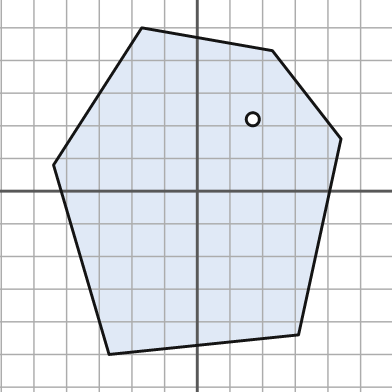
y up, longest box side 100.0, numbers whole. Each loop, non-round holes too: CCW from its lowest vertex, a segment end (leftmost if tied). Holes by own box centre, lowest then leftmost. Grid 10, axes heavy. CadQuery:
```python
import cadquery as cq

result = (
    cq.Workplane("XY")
    .moveTo(-27.0, -50.0)
    .lineTo(31.0, -44.0)
    .lineTo(44.0, 16.0)
    .lineTo(23.0, 43.0)
    .lineTo(-17.0, 50.0)
    .lineTo(-44.0, 8.0)
    .close()
    .moveTo(17.0, 22.0)
    .circle(2.0)
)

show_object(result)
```